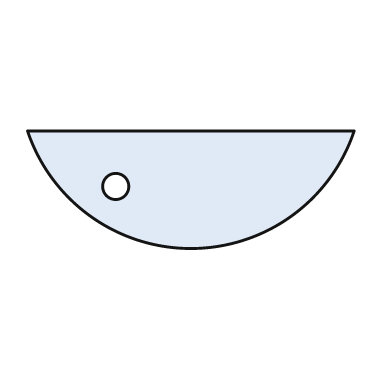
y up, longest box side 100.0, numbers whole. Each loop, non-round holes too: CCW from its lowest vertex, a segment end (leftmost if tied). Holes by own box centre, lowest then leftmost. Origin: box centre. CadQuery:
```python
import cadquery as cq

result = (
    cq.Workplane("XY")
    .moveTo(-50.0, 18.0)
    .threePointArc((0.0, -18.0), (50.0, 18.0))
    .close()
    .moveTo(-23.0, 1.0)
    .circle(4.0)
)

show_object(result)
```